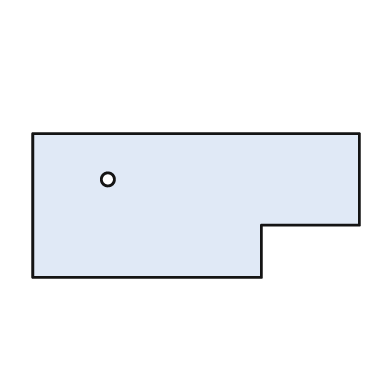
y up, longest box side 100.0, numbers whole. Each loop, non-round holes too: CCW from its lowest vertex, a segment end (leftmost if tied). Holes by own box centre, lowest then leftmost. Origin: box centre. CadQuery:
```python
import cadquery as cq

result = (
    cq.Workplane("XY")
    .moveTo(-50.0, -22.0)
    .lineTo(20.0, -22.0)
    .lineTo(20.0, -6.0)
    .lineTo(50.0, -6.0)
    .lineTo(50.0, 22.0)
    .lineTo(-50.0, 22.0)
    .close()
    .moveTo(-27.0, 8.0)
    .circle(2.0)
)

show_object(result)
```